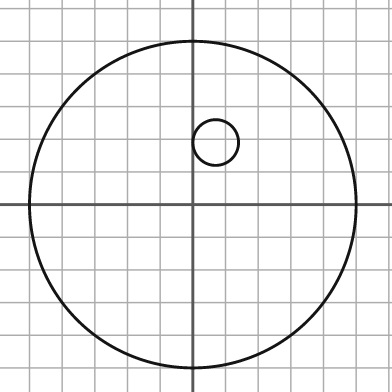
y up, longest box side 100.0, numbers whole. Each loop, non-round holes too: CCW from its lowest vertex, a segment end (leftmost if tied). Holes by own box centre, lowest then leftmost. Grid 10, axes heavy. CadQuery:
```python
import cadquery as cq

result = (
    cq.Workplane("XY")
    .moveTo(0.0, 0.0)
    .circle(50.0)
    .moveTo(7.0, 19.0)
    .circle(7.0)
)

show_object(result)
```